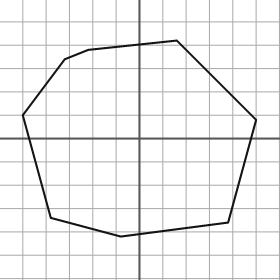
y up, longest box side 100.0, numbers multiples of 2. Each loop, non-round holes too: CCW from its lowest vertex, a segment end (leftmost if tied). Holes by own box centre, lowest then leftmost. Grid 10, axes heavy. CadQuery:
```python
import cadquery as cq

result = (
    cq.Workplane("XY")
    .moveTo(-8.0, -42.0)
    .lineTo(38.0, -36.0)
    .lineTo(50.0, 8.0)
    .lineTo(16.0, 42.0)
    .lineTo(-22.0, 38.0)
    .lineTo(-32.0, 34.0)
    .lineTo(-50.0, 10.0)
    .lineTo(-38.0, -34.0)
    .close()
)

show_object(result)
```